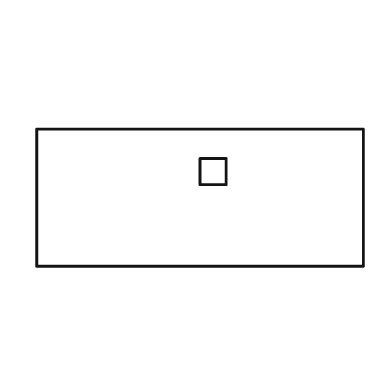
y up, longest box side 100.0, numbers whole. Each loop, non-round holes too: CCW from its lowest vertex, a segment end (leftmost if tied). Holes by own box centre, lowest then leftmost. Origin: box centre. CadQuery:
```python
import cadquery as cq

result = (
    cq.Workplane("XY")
    .moveTo(-50.0, -21.0)
    .lineTo(50.0, -21.0)
    .lineTo(50.0, 21.0)
    .lineTo(-50.0, 21.0)
    .close()
    .moveTo(0.0, 4.0)
    .lineTo(8.0, 4.0)
    .lineTo(8.0, 12.0)
    .lineTo(0.0, 12.0)
    .close()
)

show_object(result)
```